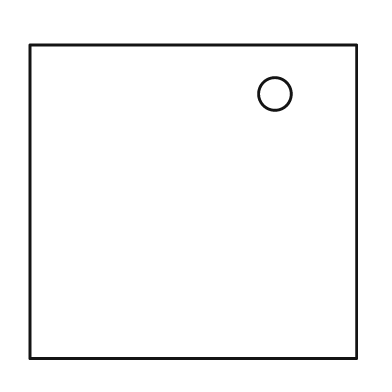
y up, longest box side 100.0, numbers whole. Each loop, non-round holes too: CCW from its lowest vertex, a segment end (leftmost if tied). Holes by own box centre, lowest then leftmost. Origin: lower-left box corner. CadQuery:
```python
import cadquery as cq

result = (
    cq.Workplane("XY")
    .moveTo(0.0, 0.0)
    .lineTo(100.0, 0.0)
    .lineTo(100.0, 96.0)
    .lineTo(0.0, 96.0)
    .close()
    .moveTo(75.0, 81.0)
    .circle(5.0)
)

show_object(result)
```